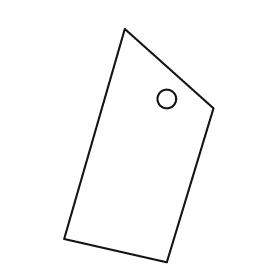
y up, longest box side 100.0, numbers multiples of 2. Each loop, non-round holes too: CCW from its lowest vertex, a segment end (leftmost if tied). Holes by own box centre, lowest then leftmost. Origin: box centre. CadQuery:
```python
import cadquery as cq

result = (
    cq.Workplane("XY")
    .moveTo(12.0, -50.0)
    .lineTo(32.0, 16.0)
    .lineTo(-6.0, 50.0)
    .lineTo(-32.0, -40.0)
    .close()
    .moveTo(12.0, 20.0)
    .circle(4.0)
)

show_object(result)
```